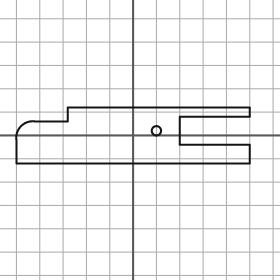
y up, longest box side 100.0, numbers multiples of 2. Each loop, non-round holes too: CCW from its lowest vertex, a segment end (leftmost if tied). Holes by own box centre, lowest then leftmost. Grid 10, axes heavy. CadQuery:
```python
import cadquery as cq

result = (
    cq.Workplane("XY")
    .moveTo(-50.0, -12.0)
    .lineTo(50.0, -12.0)
    .lineTo(50.0, -4.0)
    .lineTo(20.0, -4.0)
    .lineTo(20.0, 8.0)
    .lineTo(50.0, 8.0)
    .lineTo(50.0, 12.0)
    .lineTo(-28.0, 12.0)
    .lineTo(-28.0, 6.0)
    .lineTo(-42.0, 6.0)
    .threePointArc((-48.0, 4.0), (-50.0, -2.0))
    .close()
    .moveTo(10.0, 2.0)
    .circle(2.0)
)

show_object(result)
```